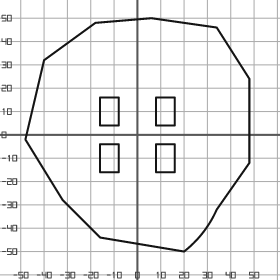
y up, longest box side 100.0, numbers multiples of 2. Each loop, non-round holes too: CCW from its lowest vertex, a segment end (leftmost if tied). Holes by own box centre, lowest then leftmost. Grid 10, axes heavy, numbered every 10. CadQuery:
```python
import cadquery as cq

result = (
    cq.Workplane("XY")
    .moveTo(20.0, -50.0)
    .threePointArc((28.0, -42.0), (34.0, -32.0))
    .lineTo(48.0, -12.0)
    .lineTo(48.0, 24.0)
    .lineTo(34.0, 46.0)
    .lineTo(6.0, 50.0)
    .lineTo(-18.0, 48.0)
    .lineTo(-40.0, 32.0)
    .lineTo(-48.0, -2.0)
    .lineTo(-32.0, -28.0)
    .lineTo(-16.0, -44.0)
    .close()
    .moveTo(-16.0, -16.0)
    .lineTo(-8.0, -16.0)
    .lineTo(-8.0, -4.0)
    .lineTo(-16.0, -4.0)
    .close()
    .moveTo(8.0, -16.0)
    .lineTo(16.0, -16.0)
    .lineTo(16.0, -4.0)
    .lineTo(8.0, -4.0)
    .close()
    .moveTo(-16.0, 4.0)
    .lineTo(-8.0, 4.0)
    .lineTo(-8.0, 16.0)
    .lineTo(-16.0, 16.0)
    .close()
    .moveTo(8.0, 4.0)
    .lineTo(16.0, 4.0)
    .lineTo(16.0, 16.0)
    .lineTo(8.0, 16.0)
    .close()
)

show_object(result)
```